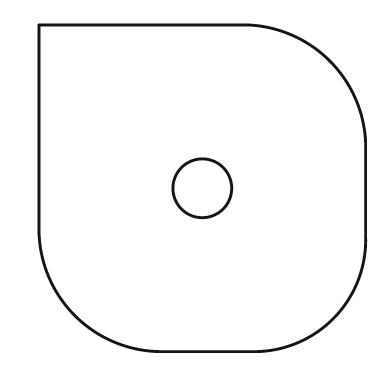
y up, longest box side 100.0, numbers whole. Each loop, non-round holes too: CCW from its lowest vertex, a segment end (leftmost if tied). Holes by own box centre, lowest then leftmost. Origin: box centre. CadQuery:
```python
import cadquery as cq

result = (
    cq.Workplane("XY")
    .moveTo(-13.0, -50.0)
    .lineTo(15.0, -50.0)
    .threePointArc((40.0, -40.0), (50.0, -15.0))
    .lineTo(50.0, 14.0)
    .threePointArc((39.0, 39.0), (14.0, 50.0))
    .lineTo(-50.0, 50.0)
    .lineTo(-50.0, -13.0)
    .threePointArc((-39.0, -39.0), (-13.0, -50.0))
    .close()
    .moveTo(0.0, 0.0)
    .circle(9.0)
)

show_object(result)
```